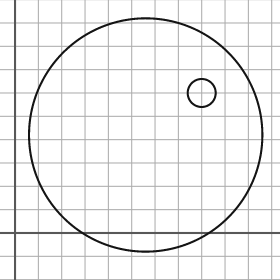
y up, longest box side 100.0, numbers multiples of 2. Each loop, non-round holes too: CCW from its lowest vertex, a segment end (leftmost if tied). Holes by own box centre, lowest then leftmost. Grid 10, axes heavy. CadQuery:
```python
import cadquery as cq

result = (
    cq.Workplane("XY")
    .moveTo(56.0, 42.0)
    .circle(50.0)
    .moveTo(80.0, 60.0)
    .circle(6.0)
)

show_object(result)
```